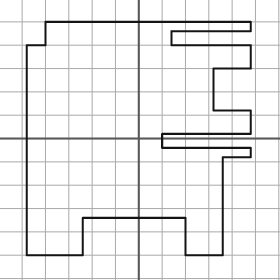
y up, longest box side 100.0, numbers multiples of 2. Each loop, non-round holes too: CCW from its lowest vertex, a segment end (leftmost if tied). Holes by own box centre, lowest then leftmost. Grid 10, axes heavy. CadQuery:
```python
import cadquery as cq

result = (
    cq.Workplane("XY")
    .moveTo(-48.0, -50.0)
    .lineTo(-24.0, -50.0)
    .lineTo(-24.0, -34.0)
    .lineTo(20.0, -34.0)
    .lineTo(20.0, -50.0)
    .lineTo(36.0, -50.0)
    .lineTo(36.0, -8.0)
    .lineTo(48.0, -8.0)
    .lineTo(48.0, -4.0)
    .lineTo(10.0, -4.0)
    .lineTo(10.0, 2.0)
    .lineTo(48.0, 2.0)
    .lineTo(48.0, 12.0)
    .lineTo(32.0, 12.0)
    .lineTo(32.0, 30.0)
    .lineTo(48.0, 30.0)
    .lineTo(48.0, 40.0)
    .lineTo(14.0, 40.0)
    .lineTo(14.0, 46.0)
    .lineTo(48.0, 46.0)
    .lineTo(48.0, 50.0)
    .lineTo(-40.0, 50.0)
    .lineTo(-40.0, 40.0)
    .lineTo(-48.0, 40.0)
    .close()
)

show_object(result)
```